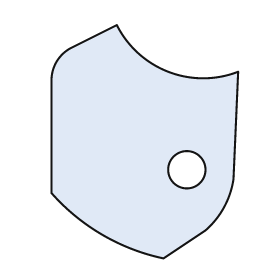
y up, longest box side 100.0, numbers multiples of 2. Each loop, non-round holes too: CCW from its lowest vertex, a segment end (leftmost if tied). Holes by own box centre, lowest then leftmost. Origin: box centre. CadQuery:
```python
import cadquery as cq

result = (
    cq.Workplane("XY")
    .moveTo(8.0, -50.0)
    .lineTo(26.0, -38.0)
    .threePointArc((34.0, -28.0), (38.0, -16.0))
    .lineTo(40.0, 30.0)
    .threePointArc((10.0, 30.0), (-12.0, 50.0))
    .lineTo(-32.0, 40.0)
    .threePointArc((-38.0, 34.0), (-40.0, 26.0))
    .lineTo(-40.0, -22.0)
    .threePointArc((-18.0, -40.0), (8.0, -50.0))
    .close()
    .moveTo(18.0, -12.0)
    .circle(8.0)
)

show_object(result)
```